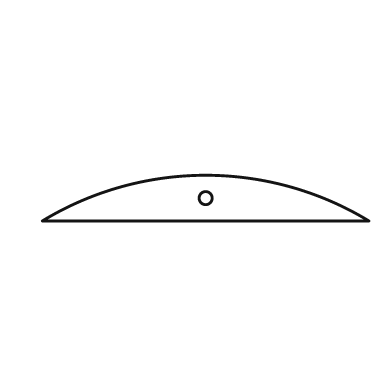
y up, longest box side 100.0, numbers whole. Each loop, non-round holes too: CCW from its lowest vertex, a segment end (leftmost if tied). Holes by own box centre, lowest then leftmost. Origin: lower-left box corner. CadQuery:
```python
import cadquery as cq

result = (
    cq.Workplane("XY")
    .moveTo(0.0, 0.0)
    .lineTo(100.0, 0.0)
    .threePointArc((50.0, 14.0), (0.0, 0.0))
    .close()
    .moveTo(50.0, 7.0)
    .circle(2.0)
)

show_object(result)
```